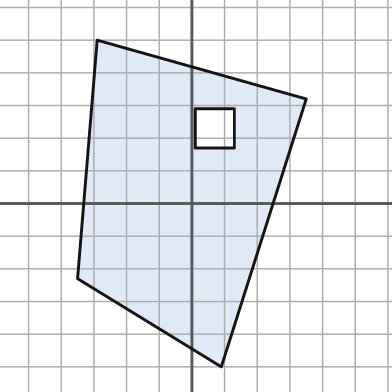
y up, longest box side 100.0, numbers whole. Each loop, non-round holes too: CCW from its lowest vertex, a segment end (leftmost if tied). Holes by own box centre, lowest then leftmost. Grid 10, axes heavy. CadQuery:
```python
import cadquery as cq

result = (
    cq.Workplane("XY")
    .moveTo(9.0, -50.0)
    .lineTo(35.0, 32.0)
    .lineTo(-29.0, 50.0)
    .lineTo(-35.0, -23.0)
    .close()
    .moveTo(1.0, 17.0)
    .lineTo(13.0, 17.0)
    .lineTo(13.0, 29.0)
    .lineTo(1.0, 29.0)
    .close()
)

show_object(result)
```